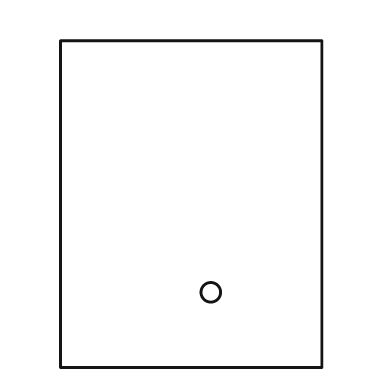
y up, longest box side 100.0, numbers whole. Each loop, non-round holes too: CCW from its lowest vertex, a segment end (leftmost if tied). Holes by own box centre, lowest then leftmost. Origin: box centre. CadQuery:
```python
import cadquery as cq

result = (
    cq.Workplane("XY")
    .moveTo(-40.0, -50.0)
    .lineTo(40.0, -50.0)
    .lineTo(40.0, 50.0)
    .lineTo(-40.0, 50.0)
    .close()
    .moveTo(6.0, -27.0)
    .circle(3.0)
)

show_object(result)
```